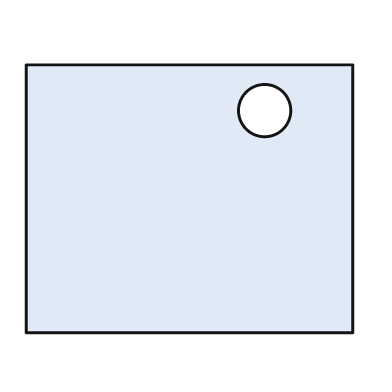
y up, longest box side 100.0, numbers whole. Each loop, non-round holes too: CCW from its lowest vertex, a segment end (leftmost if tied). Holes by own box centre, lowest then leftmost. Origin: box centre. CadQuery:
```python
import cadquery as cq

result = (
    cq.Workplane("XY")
    .moveTo(-50.0, -41.0)
    .lineTo(50.0, -41.0)
    .lineTo(50.0, 41.0)
    .lineTo(-50.0, 41.0)
    .close()
    .moveTo(23.0, 27.0)
    .circle(8.0)
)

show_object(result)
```